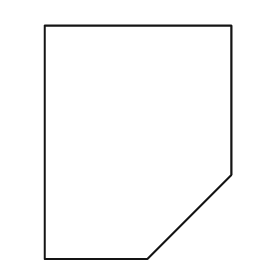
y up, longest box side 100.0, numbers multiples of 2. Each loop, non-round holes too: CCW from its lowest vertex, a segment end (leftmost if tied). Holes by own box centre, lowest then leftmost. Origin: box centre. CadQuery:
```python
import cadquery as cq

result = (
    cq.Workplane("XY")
    .moveTo(-40.0, -50.0)
    .lineTo(4.0, -50.0)
    .lineTo(40.0, -14.0)
    .lineTo(40.0, 50.0)
    .lineTo(-40.0, 50.0)
    .close()
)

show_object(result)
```